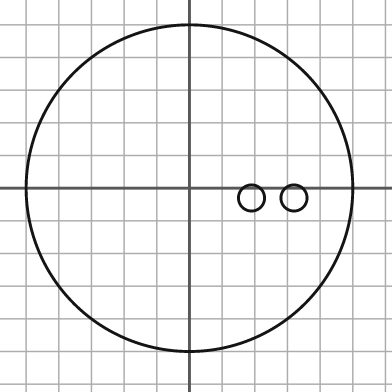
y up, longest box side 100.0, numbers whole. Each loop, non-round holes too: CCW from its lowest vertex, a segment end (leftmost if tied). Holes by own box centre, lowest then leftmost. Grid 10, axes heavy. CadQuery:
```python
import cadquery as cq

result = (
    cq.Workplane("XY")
    .moveTo(0.0, 0.0)
    .circle(50.0)
    .moveTo(19.0, -3.0)
    .circle(4.0)
    .moveTo(32.0, -3.0)
    .circle(4.0)
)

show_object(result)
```